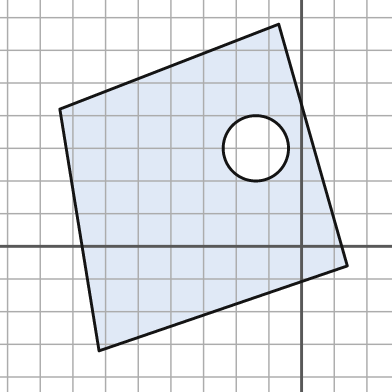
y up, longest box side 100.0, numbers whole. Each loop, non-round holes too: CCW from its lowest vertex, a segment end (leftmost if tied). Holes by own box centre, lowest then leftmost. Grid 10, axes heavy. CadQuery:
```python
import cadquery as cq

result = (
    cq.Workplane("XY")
    .moveTo(-62.0, -32.0)
    .lineTo(14.0, -6.0)
    .lineTo(-7.0, 68.0)
    .lineTo(-74.0, 42.0)
    .close()
    .moveTo(-14.0, 30.0)
    .circle(10.0)
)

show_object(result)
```